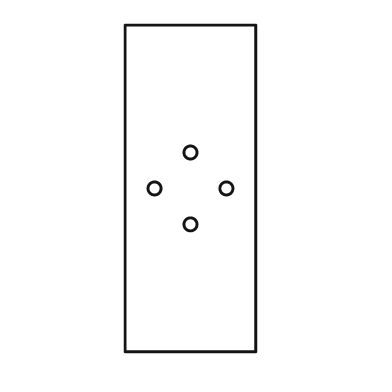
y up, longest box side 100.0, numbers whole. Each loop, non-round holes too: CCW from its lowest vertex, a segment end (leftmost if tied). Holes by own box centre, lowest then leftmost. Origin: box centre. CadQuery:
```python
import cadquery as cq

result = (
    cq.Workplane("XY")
    .moveTo(-20.0, -50.0)
    .lineTo(20.0, -50.0)
    .lineTo(20.0, 50.0)
    .lineTo(-20.0, 50.0)
    .close()
    .moveTo(0.0, -11.0)
    .circle(2.0)
    .moveTo(-11.0, 0.0)
    .circle(2.0)
    .moveTo(11.0, 0.0)
    .circle(2.0)
    .moveTo(0.0, 11.0)
    .circle(2.0)
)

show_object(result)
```